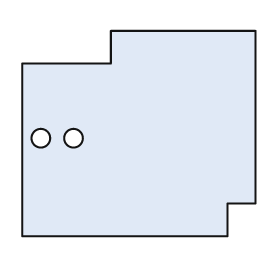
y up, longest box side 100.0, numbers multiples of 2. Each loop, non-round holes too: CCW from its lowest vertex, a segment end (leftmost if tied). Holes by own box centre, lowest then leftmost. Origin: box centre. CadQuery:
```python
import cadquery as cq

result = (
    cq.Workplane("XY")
    .moveTo(-50.0, -44.0)
    .lineTo(38.0, -44.0)
    .lineTo(38.0, -30.0)
    .lineTo(50.0, -30.0)
    .lineTo(50.0, 44.0)
    .lineTo(-12.0, 44.0)
    .lineTo(-12.0, 30.0)
    .lineTo(-50.0, 30.0)
    .close()
    .moveTo(-42.0, -2.0)
    .circle(4.0)
    .moveTo(-28.0, -2.0)
    .circle(4.0)
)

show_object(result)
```